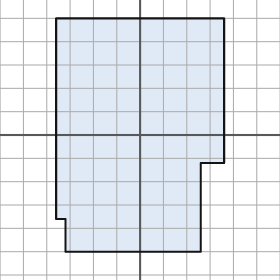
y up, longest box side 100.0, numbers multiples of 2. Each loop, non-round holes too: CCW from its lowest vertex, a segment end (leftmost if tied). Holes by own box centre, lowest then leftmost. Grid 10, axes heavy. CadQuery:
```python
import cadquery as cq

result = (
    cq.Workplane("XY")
    .moveTo(-32.0, -50.0)
    .lineTo(26.0, -50.0)
    .lineTo(26.0, -12.0)
    .lineTo(36.0, -12.0)
    .lineTo(36.0, 50.0)
    .lineTo(-36.0, 50.0)
    .lineTo(-36.0, -36.0)
    .lineTo(-32.0, -36.0)
    .close()
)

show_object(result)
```